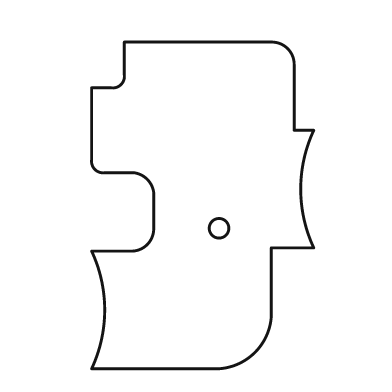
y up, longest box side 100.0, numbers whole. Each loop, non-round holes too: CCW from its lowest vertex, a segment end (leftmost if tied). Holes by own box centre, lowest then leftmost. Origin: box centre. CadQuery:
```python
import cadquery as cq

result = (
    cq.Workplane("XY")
    .moveTo(-34.0, -50.0)
    .lineTo(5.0, -50.0)
    .threePointArc((16.0, -45.0), (21.0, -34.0))
    .lineTo(21.0, -13.0)
    .lineTo(34.0, -13.0)
    .threePointArc((30.0, 5.0), (34.0, 23.0))
    .lineTo(28.0, 23.0)
    .lineTo(28.0, 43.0)
    .threePointArc((26.0, 48.0), (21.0, 50.0))
    .lineTo(-24.0, 50.0)
    .lineTo(-24.0, 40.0)
    .threePointArc((-25.0, 37.0), (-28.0, 36.0))
    .lineTo(-34.0, 36.0)
    .lineTo(-34.0, 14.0)
    .threePointArc((-33.0, 11.0), (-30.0, 10.0))
    .lineTo(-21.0, 10.0)
    .threePointArc((-17.0, 8.0), (-15.0, 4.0))
    .lineTo(-15.0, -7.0)
    .threePointArc((-17.0, -12.0), (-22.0, -14.0))
    .lineTo(-34.0, -14.0)
    .threePointArc((-30.0, -32.0), (-34.0, -50.0))
    .close()
    .moveTo(5.0, -7.0)
    .circle(3.0)
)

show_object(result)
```